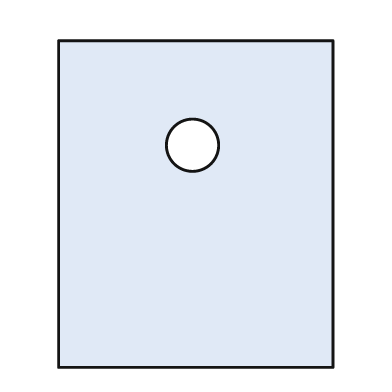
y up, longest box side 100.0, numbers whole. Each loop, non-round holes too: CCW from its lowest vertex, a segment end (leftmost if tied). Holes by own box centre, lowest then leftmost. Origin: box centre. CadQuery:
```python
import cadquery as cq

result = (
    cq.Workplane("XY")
    .moveTo(-42.0, -50.0)
    .lineTo(42.0, -50.0)
    .lineTo(42.0, 50.0)
    .lineTo(-42.0, 50.0)
    .close()
    .moveTo(-1.0, 18.0)
    .circle(8.0)
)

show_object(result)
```